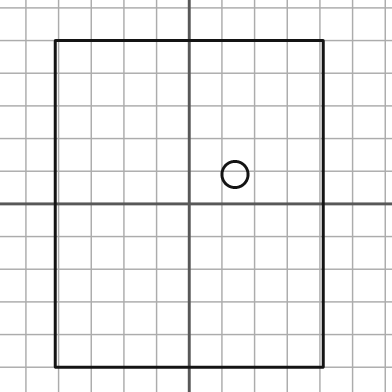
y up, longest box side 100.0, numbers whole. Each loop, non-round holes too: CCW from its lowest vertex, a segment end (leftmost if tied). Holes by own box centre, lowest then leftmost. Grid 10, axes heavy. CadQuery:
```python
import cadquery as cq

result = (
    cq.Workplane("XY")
    .moveTo(-41.0, -50.0)
    .lineTo(41.0, -50.0)
    .lineTo(41.0, 50.0)
    .lineTo(-41.0, 50.0)
    .close()
    .moveTo(14.0, 9.0)
    .circle(4.0)
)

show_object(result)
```